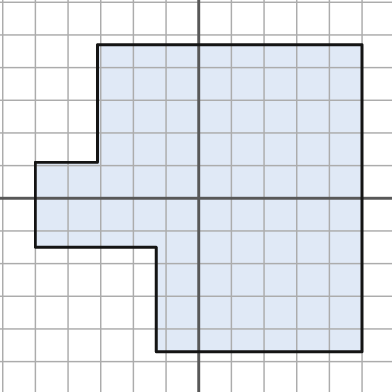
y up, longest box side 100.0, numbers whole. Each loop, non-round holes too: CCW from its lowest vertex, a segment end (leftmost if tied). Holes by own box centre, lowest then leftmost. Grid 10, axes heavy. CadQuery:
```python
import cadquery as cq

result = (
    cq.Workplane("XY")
    .moveTo(-13.0, -47.0)
    .lineTo(50.0, -47.0)
    .lineTo(50.0, 47.0)
    .lineTo(-31.0, 47.0)
    .lineTo(-31.0, 11.0)
    .lineTo(-50.0, 11.0)
    .lineTo(-50.0, -15.0)
    .lineTo(-13.0, -15.0)
    .close()
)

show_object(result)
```